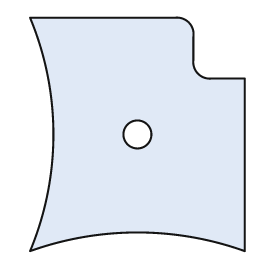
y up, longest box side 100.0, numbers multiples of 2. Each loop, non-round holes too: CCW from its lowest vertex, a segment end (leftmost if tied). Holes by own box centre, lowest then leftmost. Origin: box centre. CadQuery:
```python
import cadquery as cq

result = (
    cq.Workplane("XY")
    .moveTo(-46.0, -50.0)
    .threePointArc((0.0, -42.0), (46.0, -50.0))
    .lineTo(46.0, 24.0)
    .lineTo(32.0, 24.0)
    .threePointArc((26.0, 26.0), (24.0, 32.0))
    .lineTo(24.0, 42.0)
    .threePointArc((22.0, 48.0), (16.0, 50.0))
    .lineTo(-46.0, 50.0)
    .threePointArc((-36.0, 0.0), (-46.0, -50.0))
    .close()
    .moveTo(0.0, 0.0)
    .circle(6.0)
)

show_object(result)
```